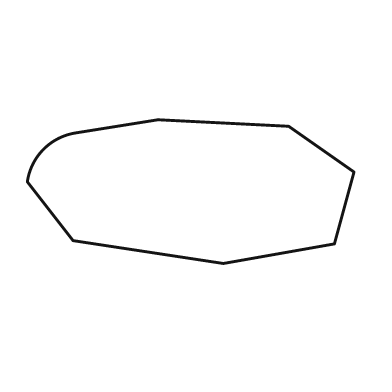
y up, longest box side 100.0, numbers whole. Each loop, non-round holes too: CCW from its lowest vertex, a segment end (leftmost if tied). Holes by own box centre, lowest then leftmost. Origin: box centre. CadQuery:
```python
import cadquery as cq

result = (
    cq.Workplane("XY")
    .moveTo(10.0, -22.0)
    .lineTo(44.0, -16.0)
    .lineTo(50.0, 6.0)
    .lineTo(30.0, 20.0)
    .lineTo(-10.0, 22.0)
    .lineTo(-35.0, 18.0)
    .threePointArc((-45.0, 13.0), (-50.0, 3.0))
    .lineTo(-36.0, -15.0)
    .close()
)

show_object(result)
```